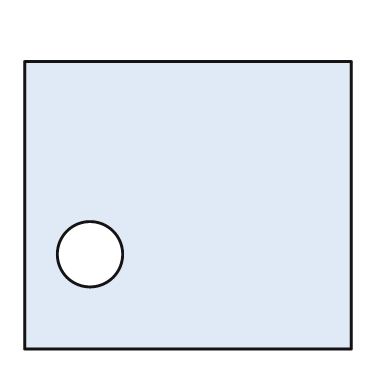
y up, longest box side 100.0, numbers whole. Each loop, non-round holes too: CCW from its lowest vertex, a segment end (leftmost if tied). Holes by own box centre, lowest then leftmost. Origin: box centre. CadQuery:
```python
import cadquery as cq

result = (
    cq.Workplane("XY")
    .moveTo(-50.0, -44.0)
    .lineTo(50.0, -44.0)
    .lineTo(50.0, 44.0)
    .lineTo(-50.0, 44.0)
    .close()
    .moveTo(-30.0, -15.0)
    .circle(10.0)
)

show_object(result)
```